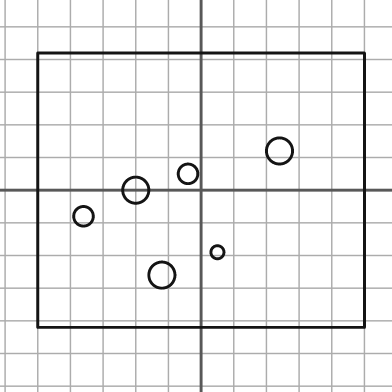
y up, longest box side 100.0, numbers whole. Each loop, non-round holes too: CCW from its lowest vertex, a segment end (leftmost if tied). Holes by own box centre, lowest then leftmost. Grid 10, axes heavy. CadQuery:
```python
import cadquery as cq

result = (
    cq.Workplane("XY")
    .moveTo(-50.0, -42.0)
    .lineTo(50.0, -42.0)
    .lineTo(50.0, 42.0)
    .lineTo(-50.0, 42.0)
    .close()
    .moveTo(-12.0, -26.0)
    .circle(4.0)
    .moveTo(5.0, -19.0)
    .circle(2.0)
    .moveTo(-36.0, -8.0)
    .circle(3.0)
    .moveTo(-20.0, 0.0)
    .circle(4.0)
    .moveTo(-4.0, 5.0)
    .circle(3.0)
    .moveTo(24.0, 12.0)
    .circle(4.0)
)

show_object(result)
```